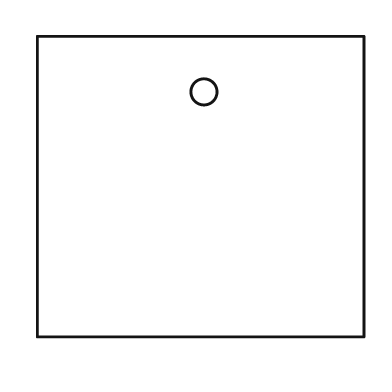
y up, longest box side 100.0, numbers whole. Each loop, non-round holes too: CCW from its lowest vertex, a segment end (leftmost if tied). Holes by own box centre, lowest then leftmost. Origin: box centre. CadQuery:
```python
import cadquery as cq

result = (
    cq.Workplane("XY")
    .moveTo(-50.0, -46.0)
    .lineTo(50.0, -46.0)
    .lineTo(50.0, 46.0)
    .lineTo(-50.0, 46.0)
    .close()
    .moveTo(1.0, 29.0)
    .circle(4.0)
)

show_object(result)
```